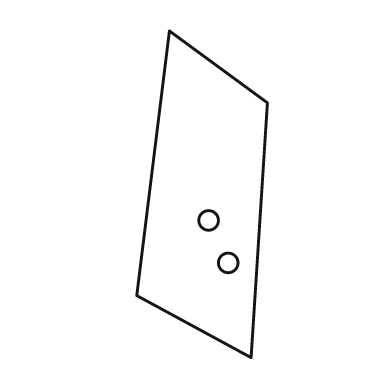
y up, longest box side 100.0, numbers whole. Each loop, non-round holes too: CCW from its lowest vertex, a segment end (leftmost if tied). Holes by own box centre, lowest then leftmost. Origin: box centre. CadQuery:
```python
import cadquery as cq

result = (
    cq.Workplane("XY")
    .moveTo(15.0, -50.0)
    .lineTo(20.0, 28.0)
    .lineTo(-10.0, 50.0)
    .lineTo(-20.0, -31.0)
    .close()
    .moveTo(8.0, -21.0)
    .circle(3.0)
    .moveTo(2.0, -8.0)
    .circle(3.0)
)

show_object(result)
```